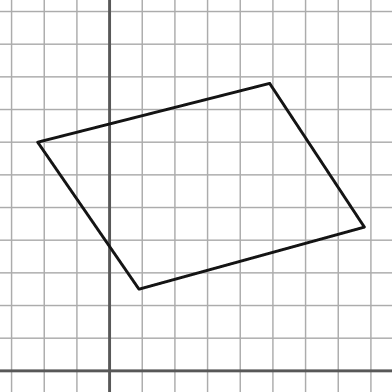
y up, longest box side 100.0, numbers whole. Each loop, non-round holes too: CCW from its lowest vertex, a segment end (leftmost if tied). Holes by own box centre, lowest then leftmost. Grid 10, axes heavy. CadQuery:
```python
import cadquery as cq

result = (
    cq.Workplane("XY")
    .moveTo(9.0, 25.0)
    .lineTo(78.0, 44.0)
    .lineTo(49.0, 88.0)
    .lineTo(-22.0, 70.0)
    .close()
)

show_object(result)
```